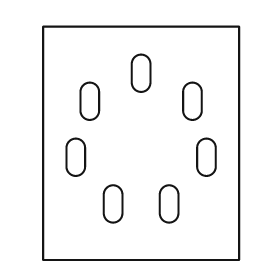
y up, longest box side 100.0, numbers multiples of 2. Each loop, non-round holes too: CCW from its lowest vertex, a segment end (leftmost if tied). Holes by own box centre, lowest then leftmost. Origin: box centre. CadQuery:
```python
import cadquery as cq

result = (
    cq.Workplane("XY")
    .moveTo(-42.0, -50.0)
    .lineTo(42.0, -50.0)
    .lineTo(42.0, 50.0)
    .lineTo(-42.0, 50.0)
    .close()
    .moveTo(-16.0, -30.0)
    .threePointArc((-12.0, -34.0), (-8.0, -30.0))
    .lineTo(-8.0, -22.0)
    .threePointArc((-12.0, -18.0), (-16.0, -22.0))
    .close()
    .moveTo(8.0, -30.0)
    .threePointArc((12.0, -34.0), (16.0, -30.0))
    .lineTo(16.0, -22.0)
    .threePointArc((12.0, -18.0), (8.0, -22.0))
    .close()
    .moveTo(-32.0, -10.0)
    .threePointArc((-28.0, -14.0), (-24.0, -10.0))
    .lineTo(-24.0, -2.0)
    .threePointArc((-28.0, 2.0), (-32.0, -2.0))
    .close()
    .moveTo(24.0, -10.0)
    .threePointArc((28.0, -14.0), (32.0, -10.0))
    .lineTo(32.0, -2.0)
    .threePointArc((28.0, 2.0), (24.0, -2.0))
    .close()
    .moveTo(-26.0, 14.0)
    .threePointArc((-22.0, 10.0), (-18.0, 14.0))
    .lineTo(-18.0, 22.0)
    .threePointArc((-22.0, 26.0), (-26.0, 22.0))
    .close()
    .moveTo(18.0, 14.0)
    .threePointArc((22.0, 10.0), (26.0, 14.0))
    .lineTo(26.0, 22.0)
    .threePointArc((22.0, 26.0), (18.0, 22.0))
    .close()
    .moveTo(-4.0, 26.0)
    .threePointArc((0.0, 22.0), (4.0, 26.0))
    .lineTo(4.0, 34.0)
    .threePointArc((0.0, 38.0), (-4.0, 34.0))
    .close()
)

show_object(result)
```